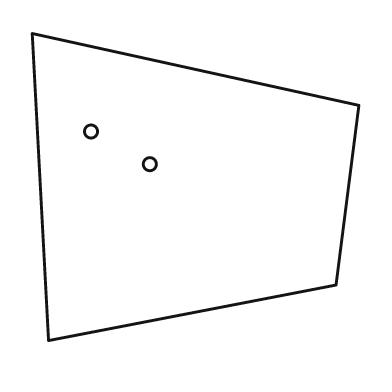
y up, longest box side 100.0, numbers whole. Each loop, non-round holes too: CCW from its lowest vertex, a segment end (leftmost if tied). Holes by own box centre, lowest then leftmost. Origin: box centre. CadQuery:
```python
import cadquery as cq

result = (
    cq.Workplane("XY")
    .moveTo(-45.0, -47.0)
    .lineTo(43.0, -30.0)
    .lineTo(50.0, 25.0)
    .lineTo(-50.0, 47.0)
    .close()
    .moveTo(-14.0, 7.0)
    .circle(2.0)
    .moveTo(-32.0, 17.0)
    .circle(2.0)
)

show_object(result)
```